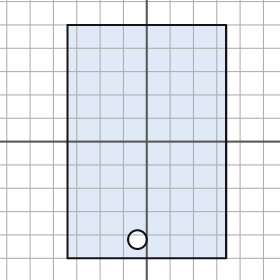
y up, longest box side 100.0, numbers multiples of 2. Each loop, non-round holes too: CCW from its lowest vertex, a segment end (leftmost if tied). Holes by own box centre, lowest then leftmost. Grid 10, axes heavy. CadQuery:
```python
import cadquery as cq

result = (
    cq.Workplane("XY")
    .moveTo(-34.0, -50.0)
    .lineTo(34.0, -50.0)
    .lineTo(34.0, 50.0)
    .lineTo(-34.0, 50.0)
    .close()
    .moveTo(-4.0, -42.0)
    .circle(4.0)
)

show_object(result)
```